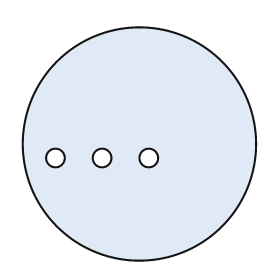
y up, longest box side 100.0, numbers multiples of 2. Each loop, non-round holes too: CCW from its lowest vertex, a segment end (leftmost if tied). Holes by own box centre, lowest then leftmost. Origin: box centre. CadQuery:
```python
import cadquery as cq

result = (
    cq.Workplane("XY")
    .moveTo(0.0, 0.0)
    .circle(50.0)
    .moveTo(-36.0, -6.0)
    .circle(4.0)
    .moveTo(-16.0, -6.0)
    .circle(4.0)
    .moveTo(4.0, -6.0)
    .circle(4.0)
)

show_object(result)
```